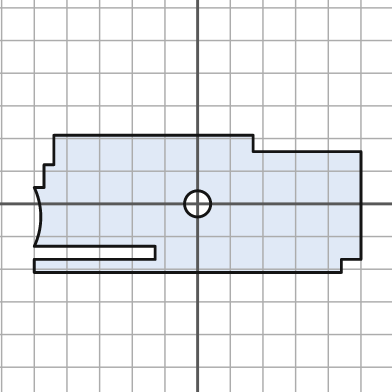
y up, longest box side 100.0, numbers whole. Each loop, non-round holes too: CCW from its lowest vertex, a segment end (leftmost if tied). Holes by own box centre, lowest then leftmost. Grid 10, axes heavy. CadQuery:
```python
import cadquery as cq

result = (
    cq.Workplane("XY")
    .moveTo(-50.0, -21.0)
    .lineTo(44.0, -21.0)
    .lineTo(44.0, -17.0)
    .lineTo(50.0, -17.0)
    .lineTo(50.0, 16.0)
    .lineTo(17.0, 16.0)
    .lineTo(17.0, 21.0)
    .lineTo(-44.0, 21.0)
    .lineTo(-44.0, 12.0)
    .lineTo(-47.0, 12.0)
    .lineTo(-47.0, 5.0)
    .lineTo(-50.0, 5.0)
    .threePointArc((-48.0, -4.0), (-50.0, -13.0))
    .lineTo(-13.0, -13.0)
    .lineTo(-13.0, -17.0)
    .lineTo(-50.0, -17.0)
    .close()
    .moveTo(0.0, 0.0)
    .circle(4.0)
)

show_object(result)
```